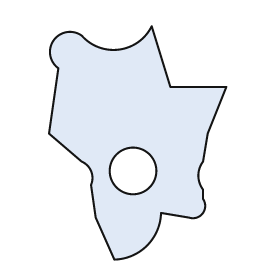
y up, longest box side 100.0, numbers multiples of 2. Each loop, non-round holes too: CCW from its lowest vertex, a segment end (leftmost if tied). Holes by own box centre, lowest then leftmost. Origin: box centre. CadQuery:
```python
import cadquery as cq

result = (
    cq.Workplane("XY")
    .moveTo(-10.0, -50.0)
    .threePointArc((4.0, -44.0), (10.0, -30.0))
    .lineTo(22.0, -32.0)
    .threePointArc((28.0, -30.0), (28.0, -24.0))
    .lineTo(28.0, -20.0)
    .threePointArc((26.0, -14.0), (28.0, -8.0))
    .lineTo(30.0, 4.0)
    .lineTo(38.0, 24.0)
    .lineTo(14.0, 24.0)
    .lineTo(6.0, 50.0)
    .threePointArc((-8.0, 40.0), (-24.0, 46.0))
    .threePointArc((-36.0, 44.0), (-34.0, 32.0))
    .lineTo(-38.0, 4.0)
    .lineTo(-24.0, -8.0)
    .threePointArc((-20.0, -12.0), (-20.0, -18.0))
    .lineTo(-18.0, -32.0)
    .close()
    .moveTo(-2.0, -12.0)
    .circle(10.0)
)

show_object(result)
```